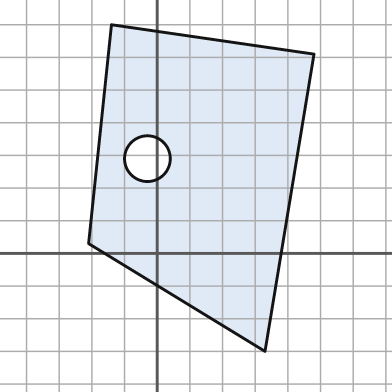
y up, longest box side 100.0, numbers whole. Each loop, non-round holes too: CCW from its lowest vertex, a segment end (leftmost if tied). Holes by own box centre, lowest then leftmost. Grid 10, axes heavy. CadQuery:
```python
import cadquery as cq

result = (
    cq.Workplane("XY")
    .moveTo(33.0, -30.0)
    .lineTo(48.0, 61.0)
    .lineTo(-14.0, 70.0)
    .lineTo(-21.0, 3.0)
    .close()
    .moveTo(-3.0, 29.0)
    .circle(7.0)
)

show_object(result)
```